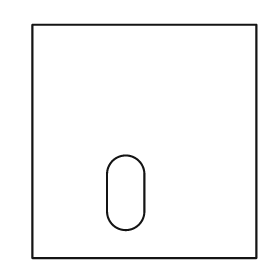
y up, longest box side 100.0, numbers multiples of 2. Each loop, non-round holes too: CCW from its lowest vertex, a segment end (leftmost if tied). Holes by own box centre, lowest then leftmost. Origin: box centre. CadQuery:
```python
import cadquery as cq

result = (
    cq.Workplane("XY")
    .moveTo(-48.0, -50.0)
    .lineTo(48.0, -50.0)
    .lineTo(48.0, 50.0)
    .lineTo(-48.0, 50.0)
    .close()
    .moveTo(-16.0, -30.0)
    .threePointArc((-8.0, -38.0), (0.0, -30.0))
    .lineTo(0.0, -14.0)
    .threePointArc((-8.0, -6.0), (-16.0, -14.0))
    .close()
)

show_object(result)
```